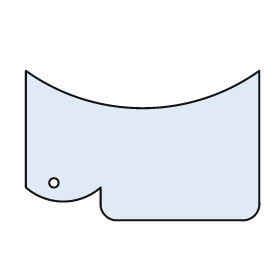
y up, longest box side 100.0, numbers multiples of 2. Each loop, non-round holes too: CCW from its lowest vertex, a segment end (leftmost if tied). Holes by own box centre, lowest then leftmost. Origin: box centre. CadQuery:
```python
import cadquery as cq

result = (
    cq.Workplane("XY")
    .moveTo(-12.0, -32.0)
    .lineTo(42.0, -32.0)
    .threePointArc((48.0, -30.0), (50.0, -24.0))
    .lineTo(50.0, 32.0)
    .threePointArc((0.0, 16.0), (-50.0, 32.0))
    .lineTo(-50.0, -18.0)
    .threePointArc((-34.0, -24.0), (-18.0, -18.0))
    .lineTo(-18.0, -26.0)
    .threePointArc((-16.0, -30.0), (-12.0, -32.0))
    .close()
    .moveTo(-38.0, -16.0)
    .circle(2.0)
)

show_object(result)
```